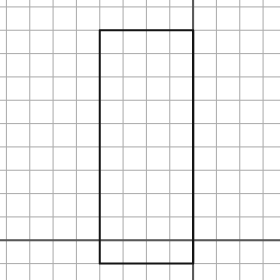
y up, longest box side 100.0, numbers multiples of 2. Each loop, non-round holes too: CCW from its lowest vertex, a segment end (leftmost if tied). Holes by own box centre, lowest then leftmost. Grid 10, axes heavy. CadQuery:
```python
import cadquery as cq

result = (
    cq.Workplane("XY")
    .moveTo(-40.0, -10.0)
    .lineTo(0.0, -10.0)
    .lineTo(0.0, 90.0)
    .lineTo(-40.0, 90.0)
    .close()
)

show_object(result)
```